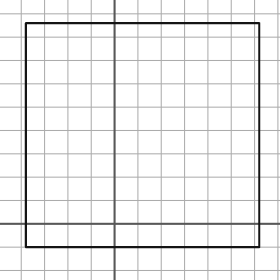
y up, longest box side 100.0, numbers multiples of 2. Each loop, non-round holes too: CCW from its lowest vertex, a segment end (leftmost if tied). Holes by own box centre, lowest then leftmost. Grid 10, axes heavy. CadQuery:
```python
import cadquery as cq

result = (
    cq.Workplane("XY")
    .moveTo(-38.0, -10.0)
    .lineTo(62.0, -10.0)
    .lineTo(62.0, 86.0)
    .lineTo(-38.0, 86.0)
    .close()
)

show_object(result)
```